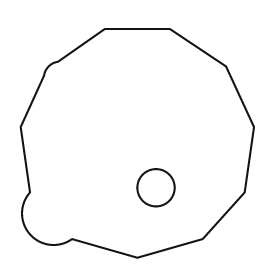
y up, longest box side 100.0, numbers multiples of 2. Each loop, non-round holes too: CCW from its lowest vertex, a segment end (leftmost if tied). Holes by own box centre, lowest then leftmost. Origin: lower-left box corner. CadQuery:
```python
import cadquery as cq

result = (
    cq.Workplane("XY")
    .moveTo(50.0, 0.0)
    .lineTo(78.0, 8.0)
    .lineTo(96.0, 28.0)
    .lineTo(100.0, 56.0)
    .lineTo(88.0, 82.0)
    .lineTo(64.0, 98.0)
    .lineTo(36.0, 98.0)
    .lineTo(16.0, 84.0)
    .threePointArc((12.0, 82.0), (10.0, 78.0))
    .lineTo(0.0, 56.0)
    .lineTo(4.0, 28.0)
    .threePointArc((4.0, 10.0), (22.0, 8.0))
    .close()
    .moveTo(58.0, 30.0)
    .circle(8.0)
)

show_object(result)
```